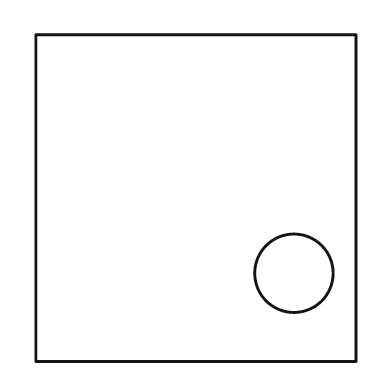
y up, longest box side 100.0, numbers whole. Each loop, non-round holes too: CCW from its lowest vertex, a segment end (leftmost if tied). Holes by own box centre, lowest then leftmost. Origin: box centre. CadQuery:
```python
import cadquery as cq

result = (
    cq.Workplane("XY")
    .moveTo(-49.0, -50.0)
    .lineTo(49.0, -50.0)
    .lineTo(49.0, 50.0)
    .lineTo(-49.0, 50.0)
    .close()
    .moveTo(30.0, -23.0)
    .circle(12.0)
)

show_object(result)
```